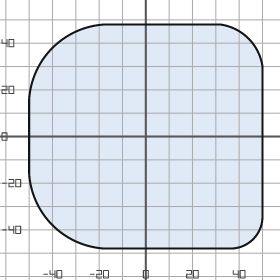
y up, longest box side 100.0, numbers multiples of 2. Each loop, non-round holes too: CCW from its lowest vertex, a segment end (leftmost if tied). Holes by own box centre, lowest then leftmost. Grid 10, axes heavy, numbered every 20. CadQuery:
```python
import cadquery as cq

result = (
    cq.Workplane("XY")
    .moveTo(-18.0, -48.0)
    .lineTo(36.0, -48.0)
    .threePointArc((46.0, -44.0), (50.0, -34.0))
    .lineTo(50.0, 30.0)
    .threePointArc((44.0, 42.0), (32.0, 48.0))
    .lineTo(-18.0, 48.0)
    .threePointArc((-40.0, 38.0), (-50.0, 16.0))
    .lineTo(-50.0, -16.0)
    .threePointArc((-40.0, -38.0), (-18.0, -48.0))
    .close()
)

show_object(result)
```